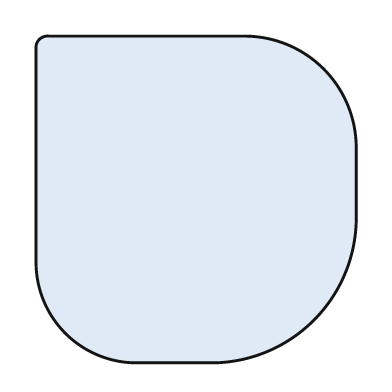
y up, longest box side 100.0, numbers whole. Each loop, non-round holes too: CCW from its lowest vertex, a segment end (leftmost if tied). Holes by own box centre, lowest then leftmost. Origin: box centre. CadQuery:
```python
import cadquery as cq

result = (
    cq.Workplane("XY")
    .moveTo(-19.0, -50.0)
    .lineTo(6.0, -50.0)
    .threePointArc((36.0, -37.0), (49.0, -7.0))
    .lineTo(49.0, 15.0)
    .threePointArc((39.0, 40.0), (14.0, 50.0))
    .lineTo(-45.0, 50.0)
    .threePointArc((-48.0, 49.0), (-49.0, 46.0))
    .lineTo(-49.0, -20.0)
    .threePointArc((-40.0, -41.0), (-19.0, -50.0))
    .close()
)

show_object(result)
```